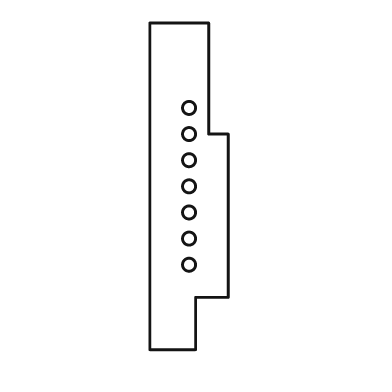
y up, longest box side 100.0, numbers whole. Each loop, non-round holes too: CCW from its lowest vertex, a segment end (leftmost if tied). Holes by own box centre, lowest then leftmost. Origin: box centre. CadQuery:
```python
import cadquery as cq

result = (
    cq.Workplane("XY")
    .moveTo(-12.0, -50.0)
    .lineTo(2.0, -50.0)
    .lineTo(2.0, -34.0)
    .lineTo(12.0, -34.0)
    .lineTo(12.0, 16.0)
    .lineTo(6.0, 16.0)
    .lineTo(6.0, 50.0)
    .lineTo(-12.0, 50.0)
    .close()
    .moveTo(0.0, -24.0)
    .circle(2.0)
    .moveTo(0.0, -16.0)
    .circle(2.0)
    .moveTo(0.0, -8.0)
    .circle(2.0)
    .moveTo(0.0, 0.0)
    .circle(2.0)
    .moveTo(0.0, 8.0)
    .circle(2.0)
    .moveTo(0.0, 16.0)
    .circle(2.0)
    .moveTo(0.0, 24.0)
    .circle(2.0)
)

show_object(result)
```